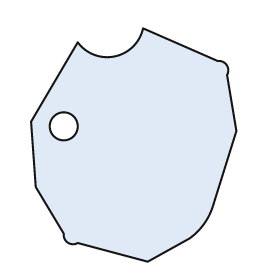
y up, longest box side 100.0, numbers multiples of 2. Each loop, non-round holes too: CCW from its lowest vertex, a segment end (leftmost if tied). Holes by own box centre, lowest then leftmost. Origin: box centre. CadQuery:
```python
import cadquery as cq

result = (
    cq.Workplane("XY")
    .moveTo(6.0, -50.0)
    .lineTo(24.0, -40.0)
    .threePointArc((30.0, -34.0), (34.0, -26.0))
    .lineTo(44.0, 6.0)
    .lineTo(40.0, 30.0)
    .threePointArc((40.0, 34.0), (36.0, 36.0))
    .lineTo(4.0, 50.0)
    .threePointArc((-8.0, 38.0), (-24.0, 44.0))
    .lineTo(-44.0, 10.0)
    .lineTo(-42.0, -18.0)
    .lineTo(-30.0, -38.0)
    .threePointArc((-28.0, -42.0), (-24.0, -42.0))
    .close()
    .moveTo(-30.0, 8.0)
    .circle(6.0)
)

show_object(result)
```